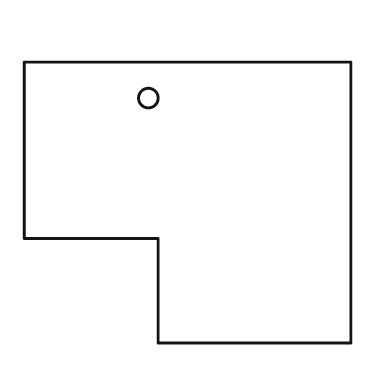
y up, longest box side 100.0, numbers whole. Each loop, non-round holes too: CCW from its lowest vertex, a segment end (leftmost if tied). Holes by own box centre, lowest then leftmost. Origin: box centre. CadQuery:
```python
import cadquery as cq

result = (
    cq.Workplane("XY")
    .moveTo(-9.0, -43.0)
    .lineTo(50.0, -43.0)
    .lineTo(50.0, 43.0)
    .lineTo(-50.0, 43.0)
    .lineTo(-50.0, -11.0)
    .lineTo(-9.0, -11.0)
    .close()
    .moveTo(-12.0, 32.0)
    .circle(3.0)
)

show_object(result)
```